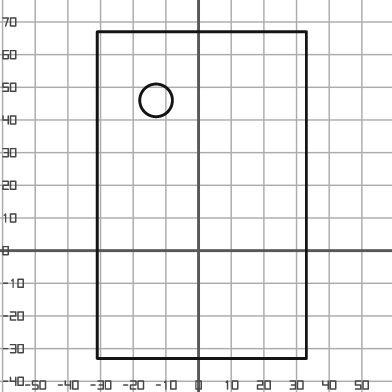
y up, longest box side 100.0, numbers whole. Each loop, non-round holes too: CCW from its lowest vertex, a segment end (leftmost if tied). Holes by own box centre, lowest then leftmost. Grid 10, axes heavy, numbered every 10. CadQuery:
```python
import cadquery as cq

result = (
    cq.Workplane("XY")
    .moveTo(-31.0, -33.0)
    .lineTo(33.0, -33.0)
    .lineTo(33.0, 67.0)
    .lineTo(-31.0, 67.0)
    .close()
    .moveTo(-13.0, 46.0)
    .circle(5.0)
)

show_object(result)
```